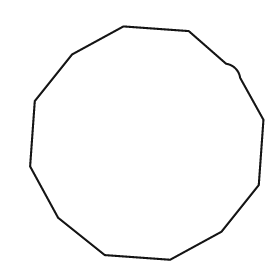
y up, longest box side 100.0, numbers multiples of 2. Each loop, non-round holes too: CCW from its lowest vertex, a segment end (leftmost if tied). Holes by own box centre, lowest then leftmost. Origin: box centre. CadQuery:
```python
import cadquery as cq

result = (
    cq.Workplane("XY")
    .moveTo(10.0, -50.0)
    .lineTo(32.0, -38.0)
    .lineTo(48.0, -18.0)
    .lineTo(50.0, 10.0)
    .lineTo(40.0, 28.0)
    .threePointArc((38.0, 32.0), (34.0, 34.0))
    .lineTo(18.0, 48.0)
    .lineTo(-10.0, 50.0)
    .lineTo(-32.0, 38.0)
    .lineTo(-48.0, 18.0)
    .lineTo(-50.0, -10.0)
    .lineTo(-38.0, -32.0)
    .lineTo(-18.0, -48.0)
    .close()
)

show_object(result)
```